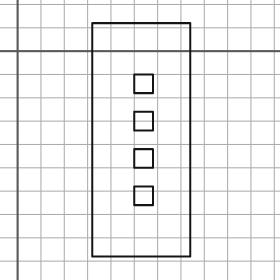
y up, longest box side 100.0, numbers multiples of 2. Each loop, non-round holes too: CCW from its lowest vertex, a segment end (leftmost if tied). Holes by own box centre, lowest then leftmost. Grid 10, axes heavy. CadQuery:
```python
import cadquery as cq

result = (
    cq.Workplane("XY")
    .moveTo(32.0, -88.0)
    .lineTo(74.0, -88.0)
    .lineTo(74.0, 12.0)
    .lineTo(32.0, 12.0)
    .close()
    .moveTo(50.0, -66.0)
    .lineTo(58.0, -66.0)
    .lineTo(58.0, -58.0)
    .lineTo(50.0, -58.0)
    .close()
    .moveTo(50.0, -50.0)
    .lineTo(58.0, -50.0)
    .lineTo(58.0, -42.0)
    .lineTo(50.0, -42.0)
    .close()
    .moveTo(50.0, -34.0)
    .lineTo(58.0, -34.0)
    .lineTo(58.0, -26.0)
    .lineTo(50.0, -26.0)
    .close()
    .moveTo(50.0, -18.0)
    .lineTo(58.0, -18.0)
    .lineTo(58.0, -10.0)
    .lineTo(50.0, -10.0)
    .close()
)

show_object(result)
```